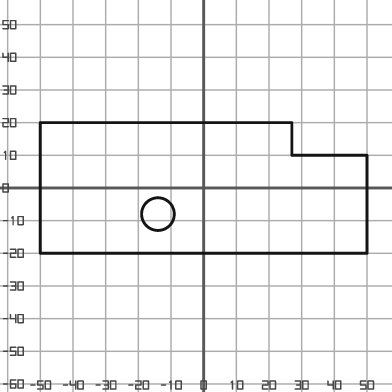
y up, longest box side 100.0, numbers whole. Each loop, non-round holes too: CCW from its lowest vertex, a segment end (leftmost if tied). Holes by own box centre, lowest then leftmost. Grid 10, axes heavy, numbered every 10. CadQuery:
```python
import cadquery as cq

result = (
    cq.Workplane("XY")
    .moveTo(-50.0, -20.0)
    .lineTo(50.0, -20.0)
    .lineTo(50.0, 10.0)
    .lineTo(27.0, 10.0)
    .lineTo(27.0, 20.0)
    .lineTo(-50.0, 20.0)
    .close()
    .moveTo(-14.0, -8.0)
    .circle(5.0)
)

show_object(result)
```